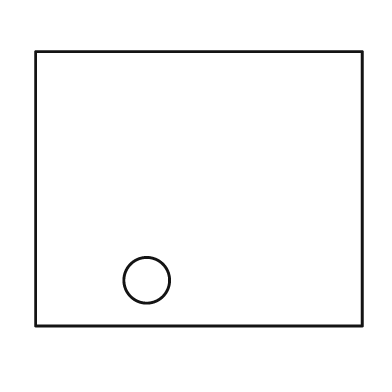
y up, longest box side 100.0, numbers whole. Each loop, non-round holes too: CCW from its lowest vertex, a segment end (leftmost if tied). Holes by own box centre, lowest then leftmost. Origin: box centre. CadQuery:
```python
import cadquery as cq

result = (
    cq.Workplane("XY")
    .moveTo(-50.0, -42.0)
    .lineTo(50.0, -42.0)
    .lineTo(50.0, 42.0)
    .lineTo(-50.0, 42.0)
    .close()
    .moveTo(-16.0, -28.0)
    .circle(7.0)
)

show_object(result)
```